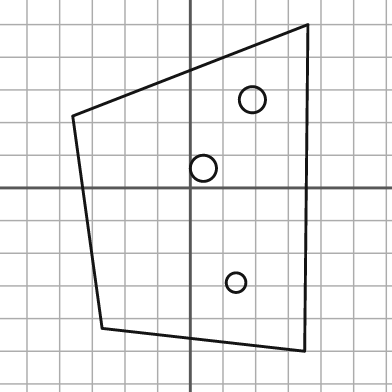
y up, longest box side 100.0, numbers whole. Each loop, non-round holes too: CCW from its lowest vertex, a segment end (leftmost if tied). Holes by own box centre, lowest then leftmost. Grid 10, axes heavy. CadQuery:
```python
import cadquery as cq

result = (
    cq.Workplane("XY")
    .moveTo(35.0, -50.0)
    .lineTo(36.0, 50.0)
    .lineTo(-36.0, 22.0)
    .lineTo(-27.0, -43.0)
    .close()
    .moveTo(14.0, -29.0)
    .circle(3.0)
    .moveTo(4.0, 6.0)
    .circle(4.0)
    .moveTo(19.0, 27.0)
    .circle(4.0)
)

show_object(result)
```